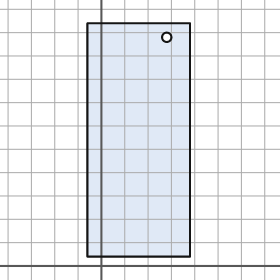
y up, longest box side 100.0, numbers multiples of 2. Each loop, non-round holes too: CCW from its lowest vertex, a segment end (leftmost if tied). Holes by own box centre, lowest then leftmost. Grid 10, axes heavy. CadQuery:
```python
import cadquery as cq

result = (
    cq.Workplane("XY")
    .moveTo(-6.0, 4.0)
    .lineTo(38.0, 4.0)
    .lineTo(38.0, 104.0)
    .lineTo(-6.0, 104.0)
    .close()
    .moveTo(28.0, 98.0)
    .circle(2.0)
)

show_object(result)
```